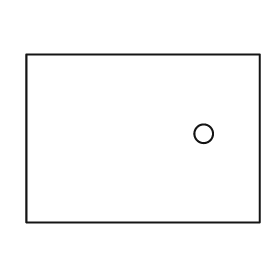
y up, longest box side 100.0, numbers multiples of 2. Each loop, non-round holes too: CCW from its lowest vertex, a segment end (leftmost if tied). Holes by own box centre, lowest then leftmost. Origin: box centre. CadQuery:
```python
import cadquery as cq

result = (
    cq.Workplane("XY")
    .moveTo(-50.0, -36.0)
    .lineTo(50.0, -36.0)
    .lineTo(50.0, 36.0)
    .lineTo(-50.0, 36.0)
    .close()
    .moveTo(26.0, 2.0)
    .circle(4.0)
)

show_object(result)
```